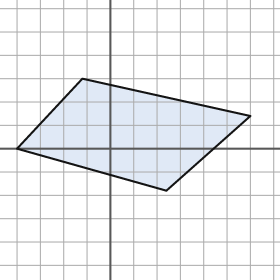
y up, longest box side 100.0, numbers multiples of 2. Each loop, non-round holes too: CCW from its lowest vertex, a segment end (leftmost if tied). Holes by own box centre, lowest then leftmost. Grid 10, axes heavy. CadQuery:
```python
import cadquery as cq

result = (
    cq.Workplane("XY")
    .moveTo(24.0, -18.0)
    .lineTo(60.0, 14.0)
    .lineTo(-12.0, 30.0)
    .lineTo(-40.0, 0.0)
    .close()
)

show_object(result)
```